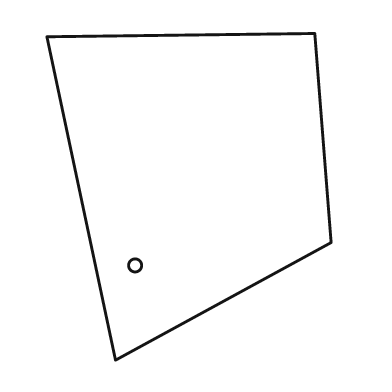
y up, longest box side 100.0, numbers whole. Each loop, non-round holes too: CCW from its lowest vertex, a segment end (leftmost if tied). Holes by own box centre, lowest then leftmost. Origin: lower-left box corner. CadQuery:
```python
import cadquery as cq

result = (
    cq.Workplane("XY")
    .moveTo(21.0, 0.0)
    .lineTo(87.0, 36.0)
    .lineTo(82.0, 100.0)
    .lineTo(0.0, 99.0)
    .close()
    .moveTo(27.0, 29.0)
    .circle(2.0)
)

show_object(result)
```